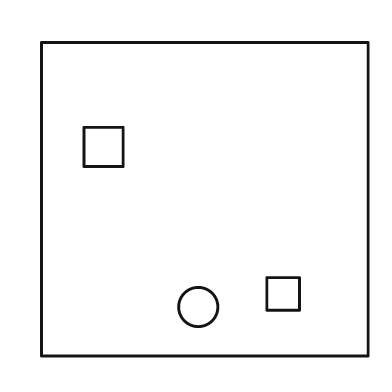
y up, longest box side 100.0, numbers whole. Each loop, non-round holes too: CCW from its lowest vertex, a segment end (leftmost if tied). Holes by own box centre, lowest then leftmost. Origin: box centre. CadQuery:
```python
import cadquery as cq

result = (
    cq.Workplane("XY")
    .moveTo(-50.0, -48.0)
    .lineTo(50.0, -48.0)
    .lineTo(50.0, 48.0)
    .lineTo(-50.0, 48.0)
    .close()
    .moveTo(-2.0, -33.0)
    .circle(6.0)
    .moveTo(19.0, -34.0)
    .lineTo(29.0, -34.0)
    .lineTo(29.0, -24.0)
    .lineTo(19.0, -24.0)
    .close()
    .moveTo(-37.0, 10.0)
    .lineTo(-25.0, 10.0)
    .lineTo(-25.0, 22.0)
    .lineTo(-37.0, 22.0)
    .close()
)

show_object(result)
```